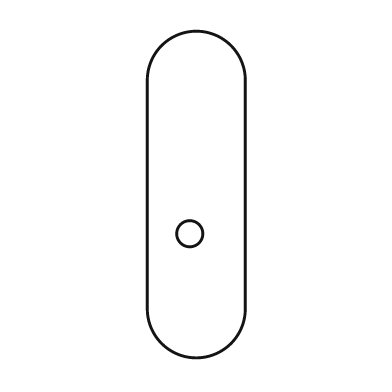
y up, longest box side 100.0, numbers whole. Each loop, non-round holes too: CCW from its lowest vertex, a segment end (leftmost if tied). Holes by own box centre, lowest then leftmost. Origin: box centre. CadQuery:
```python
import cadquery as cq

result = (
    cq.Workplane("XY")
    .moveTo(-15.0, -35.0)
    .threePointArc((0.0, -50.0), (15.0, -35.0))
    .lineTo(15.0, 35.0)
    .threePointArc((0.0, 50.0), (-15.0, 35.0))
    .close()
    .moveTo(-2.0, -12.0)
    .circle(4.0)
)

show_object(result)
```